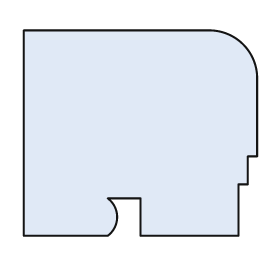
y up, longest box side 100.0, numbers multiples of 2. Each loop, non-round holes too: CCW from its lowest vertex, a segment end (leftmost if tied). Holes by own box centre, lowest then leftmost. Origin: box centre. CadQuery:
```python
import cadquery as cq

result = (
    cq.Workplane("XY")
    .moveTo(-50.0, -44.0)
    .lineTo(-14.0, -44.0)
    .threePointArc((-10.0, -36.0), (-14.0, -28.0))
    .lineTo(0.0, -28.0)
    .lineTo(0.0, -44.0)
    .lineTo(42.0, -44.0)
    .lineTo(42.0, -22.0)
    .lineTo(46.0, -22.0)
    .lineTo(46.0, -10.0)
    .lineTo(50.0, -10.0)
    .lineTo(50.0, 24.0)
    .threePointArc((44.0, 38.0), (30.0, 44.0))
    .lineTo(-50.0, 44.0)
    .close()
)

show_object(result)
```